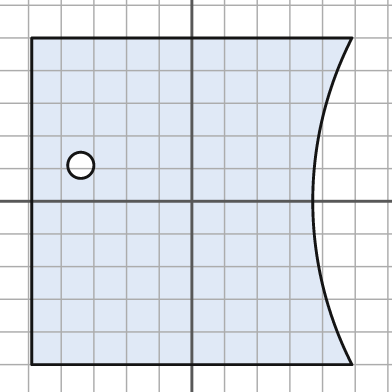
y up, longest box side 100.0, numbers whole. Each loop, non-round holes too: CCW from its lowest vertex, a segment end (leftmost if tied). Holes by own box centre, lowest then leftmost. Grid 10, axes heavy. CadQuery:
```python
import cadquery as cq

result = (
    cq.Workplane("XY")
    .moveTo(-49.0, -50.0)
    .lineTo(49.0, -50.0)
    .threePointArc((37.0, 0.0), (49.0, 50.0))
    .lineTo(-49.0, 50.0)
    .close()
    .moveTo(-34.0, 11.0)
    .circle(4.0)
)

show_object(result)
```